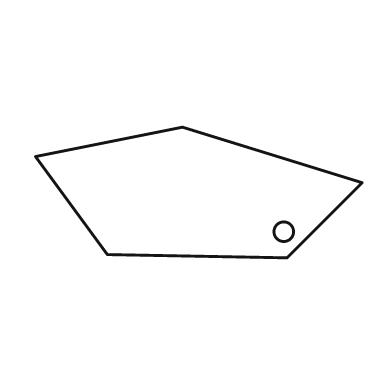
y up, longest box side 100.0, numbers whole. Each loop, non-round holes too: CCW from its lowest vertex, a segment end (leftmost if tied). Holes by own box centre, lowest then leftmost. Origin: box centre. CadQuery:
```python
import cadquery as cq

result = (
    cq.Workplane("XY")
    .moveTo(27.0, -20.0)
    .lineTo(50.0, 3.0)
    .lineTo(-5.0, 20.0)
    .lineTo(-50.0, 11.0)
    .lineTo(-28.0, -19.0)
    .close()
    .moveTo(26.0, -12.0)
    .circle(3.0)
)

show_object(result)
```